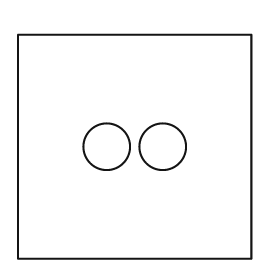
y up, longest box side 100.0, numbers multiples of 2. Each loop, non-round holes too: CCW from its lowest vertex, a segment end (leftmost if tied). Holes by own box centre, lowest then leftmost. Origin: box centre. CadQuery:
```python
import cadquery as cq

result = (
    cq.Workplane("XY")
    .moveTo(-50.0, -48.0)
    .lineTo(50.0, -48.0)
    .lineTo(50.0, 48.0)
    .lineTo(-50.0, 48.0)
    .close()
    .moveTo(-12.0, 0.0)
    .circle(10.0)
    .moveTo(12.0, 0.0)
    .circle(10.0)
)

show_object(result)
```